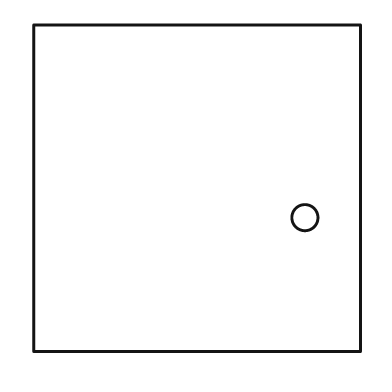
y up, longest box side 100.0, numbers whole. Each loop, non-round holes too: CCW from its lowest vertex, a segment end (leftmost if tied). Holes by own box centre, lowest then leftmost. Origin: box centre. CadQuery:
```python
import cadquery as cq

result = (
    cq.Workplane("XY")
    .moveTo(-50.0, -50.0)
    .lineTo(50.0, -50.0)
    .lineTo(50.0, 50.0)
    .lineTo(-50.0, 50.0)
    .close()
    .moveTo(33.0, -9.0)
    .circle(4.0)
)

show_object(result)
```